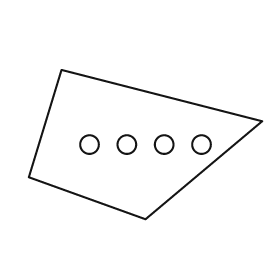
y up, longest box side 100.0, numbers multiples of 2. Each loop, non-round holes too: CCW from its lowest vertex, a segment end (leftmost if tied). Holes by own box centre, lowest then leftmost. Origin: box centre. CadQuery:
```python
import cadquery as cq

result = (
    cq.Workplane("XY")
    .moveTo(0.0, -32.0)
    .lineTo(50.0, 10.0)
    .lineTo(-36.0, 32.0)
    .lineTo(-50.0, -14.0)
    .close()
    .moveTo(-24.0, 0.0)
    .circle(4.0)
    .moveTo(-8.0, 0.0)
    .circle(4.0)
    .moveTo(8.0, 0.0)
    .circle(4.0)
    .moveTo(24.0, 0.0)
    .circle(4.0)
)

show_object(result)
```